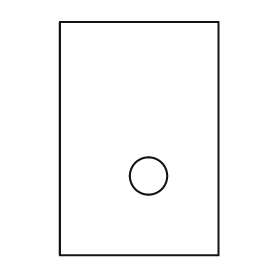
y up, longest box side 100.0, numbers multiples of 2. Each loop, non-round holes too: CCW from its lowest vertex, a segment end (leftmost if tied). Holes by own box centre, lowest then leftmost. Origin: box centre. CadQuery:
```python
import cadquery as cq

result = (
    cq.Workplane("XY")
    .moveTo(-34.0, -50.0)
    .lineTo(34.0, -50.0)
    .lineTo(34.0, 50.0)
    .lineTo(-34.0, 50.0)
    .close()
    .moveTo(4.0, -16.0)
    .circle(8.0)
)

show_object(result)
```